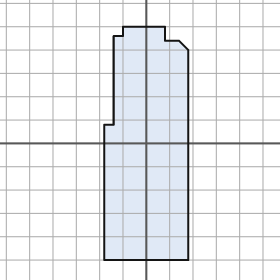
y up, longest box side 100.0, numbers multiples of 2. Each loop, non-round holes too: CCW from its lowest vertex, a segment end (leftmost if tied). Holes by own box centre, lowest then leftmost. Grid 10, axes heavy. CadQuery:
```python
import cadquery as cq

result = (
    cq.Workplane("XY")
    .moveTo(-18.0, -50.0)
    .lineTo(18.0, -50.0)
    .lineTo(18.0, 40.0)
    .lineTo(14.0, 44.0)
    .lineTo(8.0, 44.0)
    .lineTo(8.0, 50.0)
    .lineTo(-10.0, 50.0)
    .lineTo(-10.0, 46.0)
    .lineTo(-14.0, 46.0)
    .lineTo(-14.0, 8.0)
    .lineTo(-18.0, 8.0)
    .close()
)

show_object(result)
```